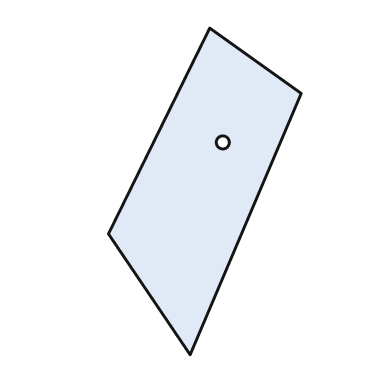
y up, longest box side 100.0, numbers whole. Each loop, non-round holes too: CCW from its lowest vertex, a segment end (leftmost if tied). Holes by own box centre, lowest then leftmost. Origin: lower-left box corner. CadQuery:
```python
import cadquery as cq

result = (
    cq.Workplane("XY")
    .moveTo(25.0, 0.0)
    .lineTo(59.0, 80.0)
    .lineTo(31.0, 100.0)
    .lineTo(0.0, 37.0)
    .close()
    .moveTo(35.0, 65.0)
    .circle(2.0)
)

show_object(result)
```